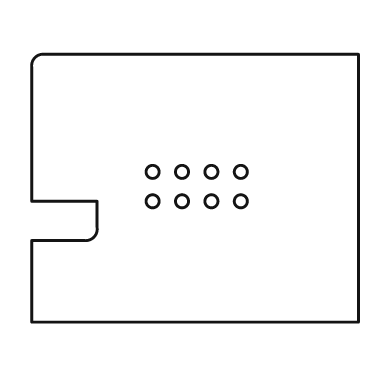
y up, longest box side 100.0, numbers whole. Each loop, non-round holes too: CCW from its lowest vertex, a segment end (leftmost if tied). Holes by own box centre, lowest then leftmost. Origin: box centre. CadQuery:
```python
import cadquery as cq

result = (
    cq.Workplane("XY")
    .moveTo(-50.0, -41.0)
    .lineTo(50.0, -41.0)
    .lineTo(50.0, 41.0)
    .lineTo(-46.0, 41.0)
    .threePointArc((-49.0, 40.0), (-50.0, 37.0))
    .lineTo(-50.0, -4.0)
    .lineTo(-30.0, -4.0)
    .lineTo(-30.0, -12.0)
    .threePointArc((-31.0, -15.0), (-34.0, -16.0))
    .lineTo(-50.0, -16.0)
    .close()
    .moveTo(-13.0, -4.0)
    .circle(2.0)
    .moveTo(-4.0, -4.0)
    .circle(2.0)
    .moveTo(5.0, -4.0)
    .circle(2.0)
    .moveTo(14.0, -4.0)
    .circle(2.0)
    .moveTo(-13.0, 5.0)
    .circle(2.0)
    .moveTo(-4.0, 5.0)
    .circle(2.0)
    .moveTo(5.0, 5.0)
    .circle(2.0)
    .moveTo(14.0, 5.0)
    .circle(2.0)
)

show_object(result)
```